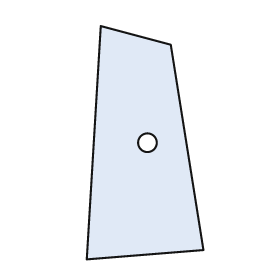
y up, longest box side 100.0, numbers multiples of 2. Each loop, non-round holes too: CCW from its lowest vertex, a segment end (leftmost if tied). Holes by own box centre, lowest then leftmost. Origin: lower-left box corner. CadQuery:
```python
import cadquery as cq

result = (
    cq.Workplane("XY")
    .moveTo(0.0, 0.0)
    .lineTo(50.0, 4.0)
    .lineTo(36.0, 92.0)
    .lineTo(6.0, 100.0)
    .close()
    .moveTo(26.0, 50.0)
    .circle(4.0)
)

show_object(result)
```